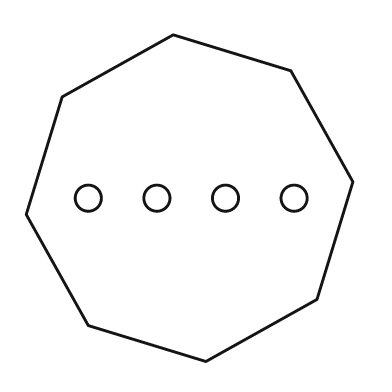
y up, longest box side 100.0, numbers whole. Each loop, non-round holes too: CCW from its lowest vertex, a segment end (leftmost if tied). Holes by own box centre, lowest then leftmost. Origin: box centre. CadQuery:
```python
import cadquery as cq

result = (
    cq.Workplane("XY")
    .moveTo(5.0, -50.0)
    .lineTo(39.0, -31.0)
    .lineTo(50.0, 5.0)
    .lineTo(31.0, 39.0)
    .lineTo(-5.0, 50.0)
    .lineTo(-39.0, 31.0)
    .lineTo(-50.0, -5.0)
    .lineTo(-31.0, -39.0)
    .close()
    .moveTo(-31.0, 0.0)
    .circle(4.0)
    .moveTo(-10.0, 0.0)
    .circle(4.0)
    .moveTo(11.0, 0.0)
    .circle(4.0)
    .moveTo(32.0, 0.0)
    .circle(4.0)
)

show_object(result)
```